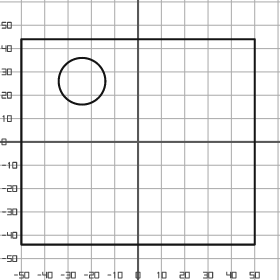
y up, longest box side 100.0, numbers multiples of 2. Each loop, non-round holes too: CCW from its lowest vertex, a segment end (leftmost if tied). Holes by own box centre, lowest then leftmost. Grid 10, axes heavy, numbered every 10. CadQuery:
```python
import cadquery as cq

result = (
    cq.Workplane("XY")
    .moveTo(-50.0, -44.0)
    .lineTo(50.0, -44.0)
    .lineTo(50.0, 44.0)
    .lineTo(-50.0, 44.0)
    .close()
    .moveTo(-24.0, 26.0)
    .circle(10.0)
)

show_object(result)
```